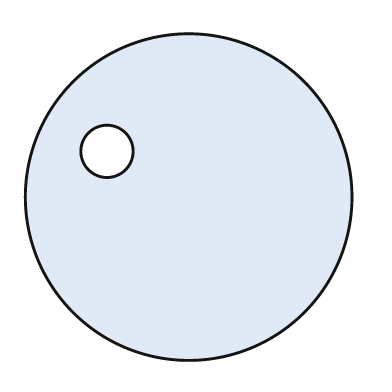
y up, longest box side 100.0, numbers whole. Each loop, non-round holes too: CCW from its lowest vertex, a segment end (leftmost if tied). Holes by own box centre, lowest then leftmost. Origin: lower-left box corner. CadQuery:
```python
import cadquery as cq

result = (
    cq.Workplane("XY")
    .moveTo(50.0, 50.0)
    .circle(50.0)
    .moveTo(25.0, 64.0)
    .circle(8.0)
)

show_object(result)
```